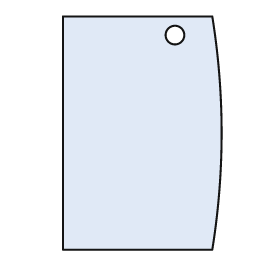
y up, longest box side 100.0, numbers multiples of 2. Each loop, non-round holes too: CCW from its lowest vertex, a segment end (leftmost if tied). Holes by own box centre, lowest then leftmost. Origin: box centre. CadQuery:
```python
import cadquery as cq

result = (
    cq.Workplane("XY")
    .moveTo(-34.0, -50.0)
    .lineTo(30.0, -50.0)
    .threePointArc((34.0, 0.0), (30.0, 50.0))
    .lineTo(-34.0, 50.0)
    .close()
    .moveTo(14.0, 42.0)
    .circle(4.0)
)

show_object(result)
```